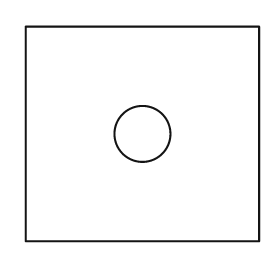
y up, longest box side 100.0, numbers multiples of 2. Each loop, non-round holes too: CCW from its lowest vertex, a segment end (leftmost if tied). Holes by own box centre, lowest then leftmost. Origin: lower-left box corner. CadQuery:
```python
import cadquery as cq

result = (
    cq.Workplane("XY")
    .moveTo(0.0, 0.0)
    .lineTo(100.0, 0.0)
    .lineTo(100.0, 92.0)
    .lineTo(0.0, 92.0)
    .close()
    .moveTo(50.0, 46.0)
    .circle(12.0)
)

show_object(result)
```